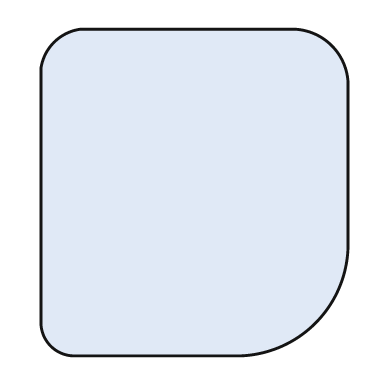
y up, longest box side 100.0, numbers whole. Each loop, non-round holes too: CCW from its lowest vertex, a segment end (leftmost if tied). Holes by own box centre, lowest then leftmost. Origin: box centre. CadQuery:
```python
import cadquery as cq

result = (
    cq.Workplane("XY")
    .moveTo(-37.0, -50.0)
    .lineTo(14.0, -50.0)
    .threePointArc((37.0, -40.0), (47.0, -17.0))
    .lineTo(47.0, 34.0)
    .threePointArc((42.0, 45.0), (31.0, 50.0))
    .lineTo(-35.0, 50.0)
    .threePointArc((-43.0, 46.0), (-47.0, 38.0))
    .lineTo(-47.0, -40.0)
    .threePointArc((-44.0, -47.0), (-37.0, -50.0))
    .close()
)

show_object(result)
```